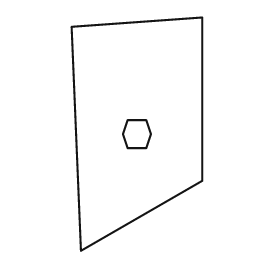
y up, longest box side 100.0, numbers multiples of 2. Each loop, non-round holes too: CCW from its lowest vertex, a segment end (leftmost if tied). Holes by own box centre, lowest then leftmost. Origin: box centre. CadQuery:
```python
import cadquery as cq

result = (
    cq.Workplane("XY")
    .moveTo(-24.0, -50.0)
    .lineTo(28.0, -20.0)
    .lineTo(28.0, 50.0)
    .lineTo(-28.0, 46.0)
    .close()
    .moveTo(-4.0, -6.0)
    .lineTo(4.0, -6.0)
    .lineTo(6.0, 0.0)
    .lineTo(4.0, 6.0)
    .lineTo(-4.0, 6.0)
    .lineTo(-6.0, 0.0)
    .close()
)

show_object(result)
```